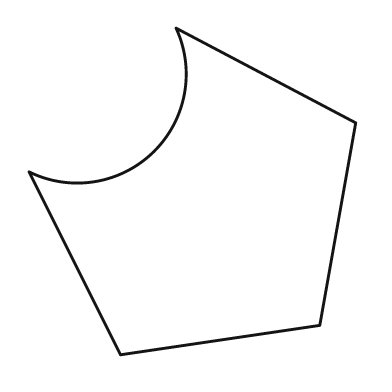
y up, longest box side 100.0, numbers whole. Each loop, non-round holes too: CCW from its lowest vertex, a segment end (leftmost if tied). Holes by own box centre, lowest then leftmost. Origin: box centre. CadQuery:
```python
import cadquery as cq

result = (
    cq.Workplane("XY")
    .moveTo(-22.0, -50.0)
    .lineTo(39.0, -41.0)
    .lineTo(50.0, 21.0)
    .lineTo(-5.0, 50.0)
    .threePointArc((-12.0, 12.0), (-50.0, 6.0))
    .close()
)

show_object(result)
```